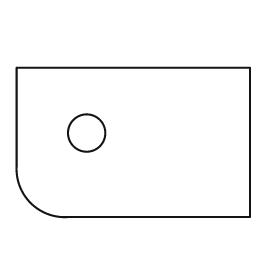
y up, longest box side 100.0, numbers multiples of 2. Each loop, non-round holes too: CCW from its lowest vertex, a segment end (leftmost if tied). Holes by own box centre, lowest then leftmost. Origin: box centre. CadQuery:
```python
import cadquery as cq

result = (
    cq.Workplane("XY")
    .moveTo(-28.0, -32.0)
    .lineTo(50.0, -32.0)
    .lineTo(50.0, 32.0)
    .lineTo(-50.0, 32.0)
    .lineTo(-50.0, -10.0)
    .threePointArc((-44.0, -26.0), (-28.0, -32.0))
    .close()
    .moveTo(-20.0, 4.0)
    .circle(8.0)
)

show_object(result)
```